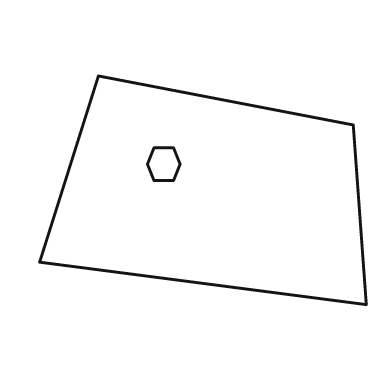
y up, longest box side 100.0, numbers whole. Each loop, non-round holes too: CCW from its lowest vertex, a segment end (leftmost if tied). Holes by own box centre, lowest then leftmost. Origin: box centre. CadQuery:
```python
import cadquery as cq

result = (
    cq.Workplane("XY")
    .moveTo(50.0, -35.0)
    .lineTo(46.0, 20.0)
    .lineTo(-32.0, 35.0)
    .lineTo(-50.0, -22.0)
    .close()
    .moveTo(-15.0, 3.0)
    .lineTo(-9.0, 3.0)
    .lineTo(-7.0, 8.0)
    .lineTo(-9.0, 13.0)
    .lineTo(-15.0, 13.0)
    .lineTo(-17.0, 8.0)
    .close()
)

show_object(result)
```